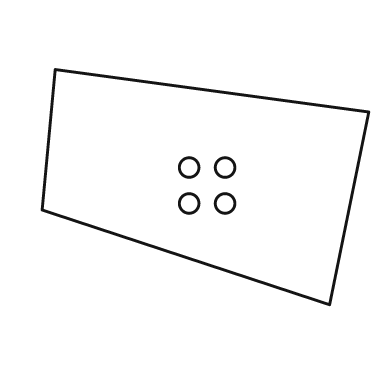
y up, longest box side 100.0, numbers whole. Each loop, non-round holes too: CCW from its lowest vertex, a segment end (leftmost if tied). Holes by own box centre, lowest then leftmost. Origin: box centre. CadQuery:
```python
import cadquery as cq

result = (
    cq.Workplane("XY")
    .moveTo(38.0, -36.0)
    .lineTo(50.0, 23.0)
    .lineTo(-46.0, 36.0)
    .lineTo(-50.0, -7.0)
    .close()
    .moveTo(-5.0, -5.0)
    .circle(3.0)
    .moveTo(6.0, -5.0)
    .circle(3.0)
    .moveTo(-5.0, 6.0)
    .circle(3.0)
    .moveTo(6.0, 6.0)
    .circle(3.0)
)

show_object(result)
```